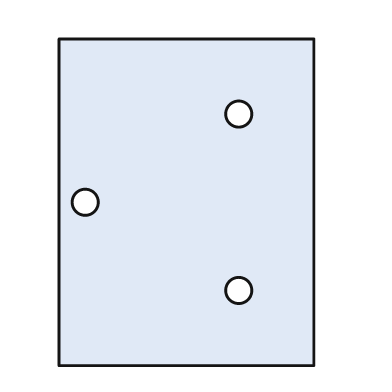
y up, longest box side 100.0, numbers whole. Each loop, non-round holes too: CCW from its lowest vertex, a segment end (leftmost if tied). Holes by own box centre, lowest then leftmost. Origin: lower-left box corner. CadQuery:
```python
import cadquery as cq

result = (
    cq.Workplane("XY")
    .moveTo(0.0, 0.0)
    .lineTo(78.0, 0.0)
    .lineTo(78.0, 100.0)
    .lineTo(0.0, 100.0)
    .close()
    .moveTo(55.0, 23.0)
    .circle(4.0)
    .moveTo(8.0, 50.0)
    .circle(4.0)
    .moveTo(55.0, 77.0)
    .circle(4.0)
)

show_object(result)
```